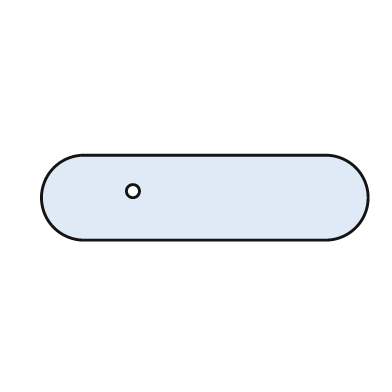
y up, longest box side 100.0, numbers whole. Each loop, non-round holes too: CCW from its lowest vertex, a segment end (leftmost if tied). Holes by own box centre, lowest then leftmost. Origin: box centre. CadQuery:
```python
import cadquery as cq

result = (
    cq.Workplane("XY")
    .moveTo(-37.0, -13.0)
    .lineTo(37.0, -13.0)
    .threePointArc((50.0, 0.0), (37.0, 13.0))
    .lineTo(-37.0, 13.0)
    .threePointArc((-50.0, 0.0), (-37.0, -13.0))
    .close()
    .moveTo(-22.0, 2.0)
    .circle(2.0)
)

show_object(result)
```